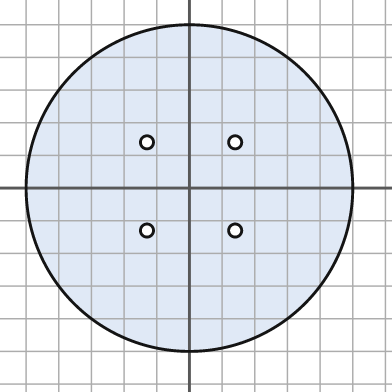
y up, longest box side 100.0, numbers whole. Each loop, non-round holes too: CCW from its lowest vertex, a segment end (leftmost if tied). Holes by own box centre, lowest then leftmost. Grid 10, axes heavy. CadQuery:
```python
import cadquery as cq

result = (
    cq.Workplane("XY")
    .moveTo(0.0, 0.0)
    .circle(50.0)
    .moveTo(-13.0, -13.0)
    .circle(2.0)
    .moveTo(14.0, -13.0)
    .circle(2.0)
    .moveTo(-13.0, 14.0)
    .circle(2.0)
    .moveTo(14.0, 14.0)
    .circle(2.0)
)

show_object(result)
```